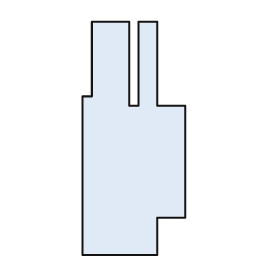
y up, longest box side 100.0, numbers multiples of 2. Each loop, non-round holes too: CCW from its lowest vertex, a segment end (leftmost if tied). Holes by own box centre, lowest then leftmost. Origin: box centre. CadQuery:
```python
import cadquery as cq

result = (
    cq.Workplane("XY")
    .moveTo(-22.0, -50.0)
    .lineTo(10.0, -50.0)
    .lineTo(10.0, -34.0)
    .lineTo(22.0, -34.0)
    .lineTo(22.0, 14.0)
    .lineTo(10.0, 14.0)
    .lineTo(10.0, 50.0)
    .lineTo(2.0, 50.0)
    .lineTo(2.0, 14.0)
    .lineTo(-2.0, 14.0)
    .lineTo(-2.0, 50.0)
    .lineTo(-18.0, 50.0)
    .lineTo(-18.0, 18.0)
    .lineTo(-22.0, 18.0)
    .close()
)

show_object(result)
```